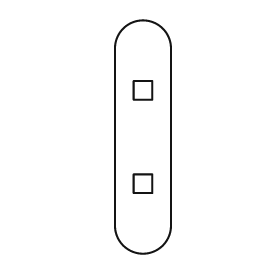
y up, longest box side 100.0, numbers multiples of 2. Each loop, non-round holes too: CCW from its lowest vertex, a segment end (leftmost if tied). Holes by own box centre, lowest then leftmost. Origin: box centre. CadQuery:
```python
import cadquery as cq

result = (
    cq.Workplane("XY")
    .moveTo(-12.0, -38.0)
    .threePointArc((0.0, -50.0), (12.0, -38.0))
    .lineTo(12.0, 38.0)
    .threePointArc((0.0, 50.0), (-12.0, 38.0))
    .close()
    .moveTo(-4.0, -24.0)
    .lineTo(4.0, -24.0)
    .lineTo(4.0, -16.0)
    .lineTo(-4.0, -16.0)
    .close()
    .moveTo(-4.0, 16.0)
    .lineTo(4.0, 16.0)
    .lineTo(4.0, 24.0)
    .lineTo(-4.0, 24.0)
    .close()
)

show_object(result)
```